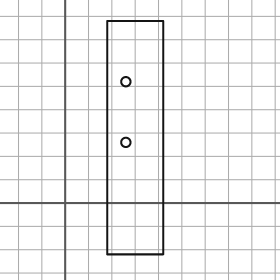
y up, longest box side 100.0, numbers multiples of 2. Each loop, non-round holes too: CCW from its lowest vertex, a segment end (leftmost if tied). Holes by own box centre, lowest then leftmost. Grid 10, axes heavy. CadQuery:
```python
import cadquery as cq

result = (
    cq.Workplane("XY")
    .moveTo(18.0, -22.0)
    .lineTo(42.0, -22.0)
    .lineTo(42.0, 78.0)
    .lineTo(18.0, 78.0)
    .close()
    .moveTo(26.0, 26.0)
    .circle(2.0)
    .moveTo(26.0, 52.0)
    .circle(2.0)
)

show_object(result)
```